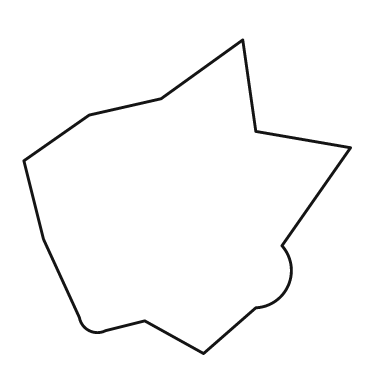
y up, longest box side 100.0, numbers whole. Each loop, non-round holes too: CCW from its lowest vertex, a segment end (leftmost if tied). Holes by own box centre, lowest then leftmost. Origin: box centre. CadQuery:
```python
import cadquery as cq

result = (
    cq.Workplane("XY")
    .moveTo(5.0, -48.0)
    .lineTo(21.0, -34.0)
    .threePointArc((31.0, -27.0), (29.0, -15.0))
    .lineTo(50.0, 15.0)
    .lineTo(21.0, 20.0)
    .lineTo(17.0, 48.0)
    .lineTo(-8.0, 30.0)
    .lineTo(-30.0, 25.0)
    .lineTo(-50.0, 11.0)
    .lineTo(-44.0, -13.0)
    .lineTo(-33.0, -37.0)
    .threePointArc((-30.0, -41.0), (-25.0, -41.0))
    .lineTo(-13.0, -38.0)
    .close()
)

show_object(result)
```